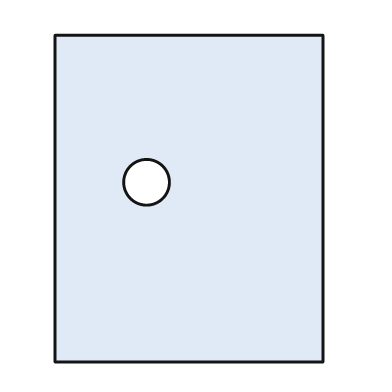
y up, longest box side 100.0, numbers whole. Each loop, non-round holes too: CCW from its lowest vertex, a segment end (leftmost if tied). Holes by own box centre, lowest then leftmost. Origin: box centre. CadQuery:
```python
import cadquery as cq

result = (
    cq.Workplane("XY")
    .moveTo(-41.0, -50.0)
    .lineTo(41.0, -50.0)
    .lineTo(41.0, 50.0)
    .lineTo(-41.0, 50.0)
    .close()
    .moveTo(-13.0, 5.0)
    .circle(7.0)
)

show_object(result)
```